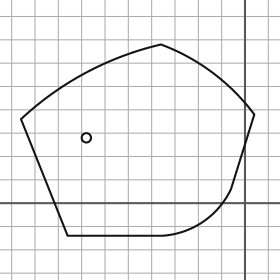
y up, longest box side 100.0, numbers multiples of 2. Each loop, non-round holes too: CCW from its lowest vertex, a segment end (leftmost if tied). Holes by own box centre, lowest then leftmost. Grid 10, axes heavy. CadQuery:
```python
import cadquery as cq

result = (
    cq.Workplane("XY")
    .moveTo(-76.0, -14.0)
    .lineTo(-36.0, -14.0)
    .threePointArc((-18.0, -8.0), (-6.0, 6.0))
    .lineTo(4.0, 38.0)
    .threePointArc((-14.0, 56.0), (-36.0, 68.0))
    .threePointArc((-68.0, 56.0), (-96.0, 36.0))
    .close()
    .moveTo(-68.0, 28.0)
    .circle(2.0)
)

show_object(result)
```